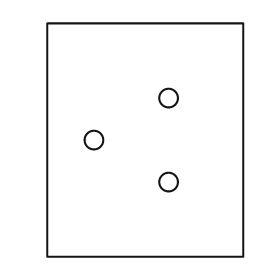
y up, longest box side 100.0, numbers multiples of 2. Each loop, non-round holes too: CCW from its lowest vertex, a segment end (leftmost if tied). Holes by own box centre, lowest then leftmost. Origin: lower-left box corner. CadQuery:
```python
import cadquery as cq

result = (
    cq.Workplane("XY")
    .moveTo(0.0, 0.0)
    .lineTo(84.0, 0.0)
    .lineTo(84.0, 100.0)
    .lineTo(0.0, 100.0)
    .close()
    .moveTo(52.0, 32.0)
    .circle(4.0)
    .moveTo(20.0, 50.0)
    .circle(4.0)
    .moveTo(52.0, 68.0)
    .circle(4.0)
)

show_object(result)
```